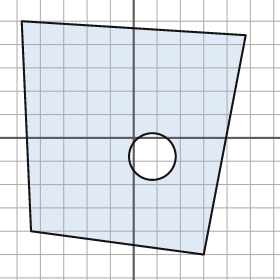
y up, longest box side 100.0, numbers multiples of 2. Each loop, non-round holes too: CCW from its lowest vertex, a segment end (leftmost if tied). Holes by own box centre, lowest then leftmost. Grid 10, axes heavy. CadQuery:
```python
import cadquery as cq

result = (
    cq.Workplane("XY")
    .moveTo(30.0, -50.0)
    .lineTo(48.0, 44.0)
    .lineTo(-48.0, 50.0)
    .lineTo(-44.0, -40.0)
    .close()
    .moveTo(8.0, -8.0)
    .circle(10.0)
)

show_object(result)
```